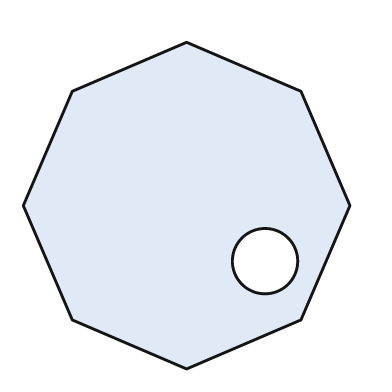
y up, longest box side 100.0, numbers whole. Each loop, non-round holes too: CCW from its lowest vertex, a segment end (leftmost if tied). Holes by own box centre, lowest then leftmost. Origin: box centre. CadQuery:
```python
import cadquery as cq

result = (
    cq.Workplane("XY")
    .moveTo(0.0, -50.0)
    .lineTo(35.0, -35.0)
    .lineTo(50.0, 0.0)
    .lineTo(35.0, 35.0)
    .lineTo(0.0, 50.0)
    .lineTo(-35.0, 35.0)
    .lineTo(-50.0, 0.0)
    .lineTo(-35.0, -35.0)
    .close()
    .moveTo(24.0, -17.0)
    .circle(10.0)
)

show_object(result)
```